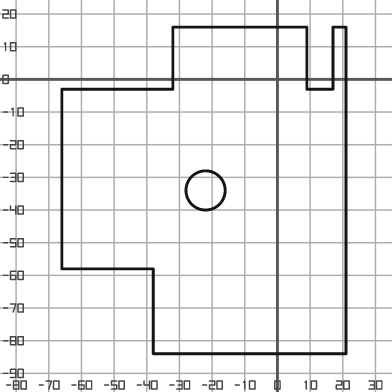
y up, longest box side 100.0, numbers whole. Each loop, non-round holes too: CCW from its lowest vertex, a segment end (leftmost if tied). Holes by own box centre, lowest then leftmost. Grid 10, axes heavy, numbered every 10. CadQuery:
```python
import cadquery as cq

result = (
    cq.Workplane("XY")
    .moveTo(-38.0, -84.0)
    .lineTo(21.0, -84.0)
    .lineTo(21.0, 16.0)
    .lineTo(17.0, 16.0)
    .lineTo(17.0, -3.0)
    .lineTo(9.0, -3.0)
    .lineTo(9.0, 16.0)
    .lineTo(-32.0, 16.0)
    .lineTo(-32.0, -3.0)
    .lineTo(-66.0, -3.0)
    .lineTo(-66.0, -58.0)
    .lineTo(-38.0, -58.0)
    .close()
    .moveTo(-22.0, -34.0)
    .circle(6.0)
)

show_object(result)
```